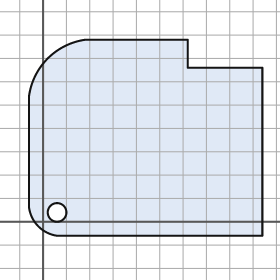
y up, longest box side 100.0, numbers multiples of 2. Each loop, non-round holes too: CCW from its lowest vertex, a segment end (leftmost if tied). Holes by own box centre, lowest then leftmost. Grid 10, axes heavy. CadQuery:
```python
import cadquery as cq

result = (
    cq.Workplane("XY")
    .moveTo(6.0, -6.0)
    .lineTo(94.0, -6.0)
    .lineTo(94.0, 66.0)
    .lineTo(62.0, 66.0)
    .lineTo(62.0, 78.0)
    .lineTo(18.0, 78.0)
    .threePointArc((2.0, 70.0), (-6.0, 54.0))
    .lineTo(-6.0, 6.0)
    .threePointArc((-2.0, -2.0), (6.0, -6.0))
    .close()
    .moveTo(6.0, 4.0)
    .circle(4.0)
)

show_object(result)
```